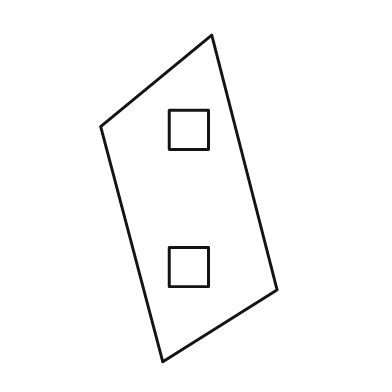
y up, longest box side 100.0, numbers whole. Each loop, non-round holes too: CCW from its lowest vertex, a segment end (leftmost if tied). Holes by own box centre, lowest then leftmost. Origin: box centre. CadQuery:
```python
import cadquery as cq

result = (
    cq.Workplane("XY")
    .moveTo(-8.0, -50.0)
    .lineTo(27.0, -28.0)
    .lineTo(7.0, 50.0)
    .lineTo(-27.0, 22.0)
    .close()
    .moveTo(-6.0, -27.0)
    .lineTo(6.0, -27.0)
    .lineTo(6.0, -15.0)
    .lineTo(-6.0, -15.0)
    .close()
    .moveTo(-6.0, 15.0)
    .lineTo(6.0, 15.0)
    .lineTo(6.0, 27.0)
    .lineTo(-6.0, 27.0)
    .close()
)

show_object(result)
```